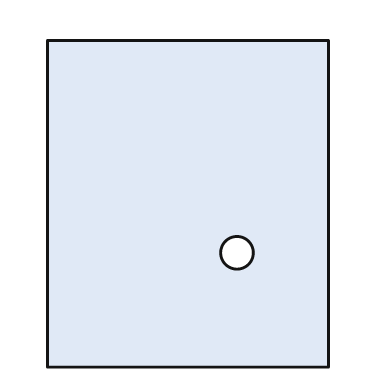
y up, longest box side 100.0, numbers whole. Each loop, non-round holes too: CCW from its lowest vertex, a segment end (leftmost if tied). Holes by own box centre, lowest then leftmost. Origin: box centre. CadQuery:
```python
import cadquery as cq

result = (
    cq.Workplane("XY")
    .moveTo(-43.0, -50.0)
    .lineTo(43.0, -50.0)
    .lineTo(43.0, 50.0)
    .lineTo(-43.0, 50.0)
    .close()
    .moveTo(15.0, -15.0)
    .circle(5.0)
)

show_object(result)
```